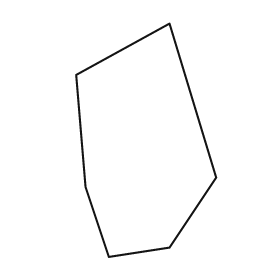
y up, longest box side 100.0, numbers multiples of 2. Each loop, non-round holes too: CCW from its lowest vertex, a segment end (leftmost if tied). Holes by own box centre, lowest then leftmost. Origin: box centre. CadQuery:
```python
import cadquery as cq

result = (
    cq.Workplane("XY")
    .moveTo(-16.0, -50.0)
    .lineTo(10.0, -46.0)
    .lineTo(30.0, -16.0)
    .lineTo(10.0, 50.0)
    .lineTo(-30.0, 28.0)
    .lineTo(-26.0, -20.0)
    .close()
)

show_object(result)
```